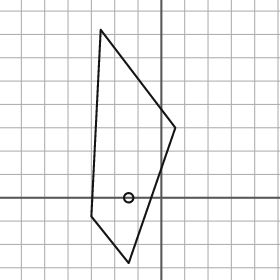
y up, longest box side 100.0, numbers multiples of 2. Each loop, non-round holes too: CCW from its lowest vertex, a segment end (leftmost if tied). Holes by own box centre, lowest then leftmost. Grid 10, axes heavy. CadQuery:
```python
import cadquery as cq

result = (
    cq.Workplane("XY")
    .moveTo(-14.0, -28.0)
    .lineTo(6.0, 30.0)
    .lineTo(-26.0, 72.0)
    .lineTo(-30.0, -8.0)
    .close()
    .moveTo(-14.0, 0.0)
    .circle(2.0)
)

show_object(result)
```